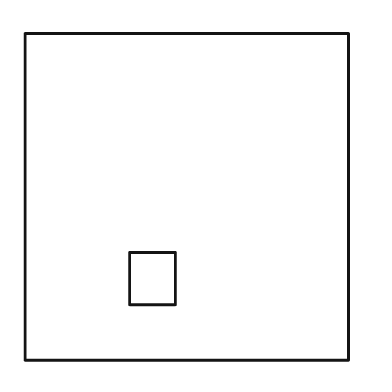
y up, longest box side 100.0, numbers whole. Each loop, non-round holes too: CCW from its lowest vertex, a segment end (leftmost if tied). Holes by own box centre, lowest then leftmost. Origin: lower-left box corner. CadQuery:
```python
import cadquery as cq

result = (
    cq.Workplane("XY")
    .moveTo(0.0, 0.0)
    .lineTo(99.0, 0.0)
    .lineTo(99.0, 100.0)
    .lineTo(0.0, 100.0)
    .close()
    .moveTo(32.0, 17.0)
    .lineTo(46.0, 17.0)
    .lineTo(46.0, 33.0)
    .lineTo(32.0, 33.0)
    .close()
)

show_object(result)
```